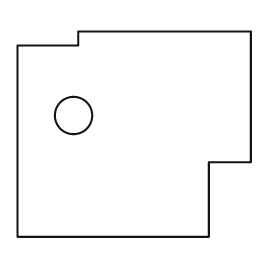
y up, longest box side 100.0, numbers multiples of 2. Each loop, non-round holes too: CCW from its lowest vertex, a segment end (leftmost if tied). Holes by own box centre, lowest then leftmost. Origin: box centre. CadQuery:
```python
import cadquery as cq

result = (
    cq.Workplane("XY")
    .moveTo(-50.0, -44.0)
    .lineTo(32.0, -44.0)
    .lineTo(32.0, -12.0)
    .lineTo(50.0, -12.0)
    .lineTo(50.0, 44.0)
    .lineTo(-24.0, 44.0)
    .lineTo(-24.0, 38.0)
    .lineTo(-50.0, 38.0)
    .close()
    .moveTo(-26.0, 8.0)
    .circle(8.0)
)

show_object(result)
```